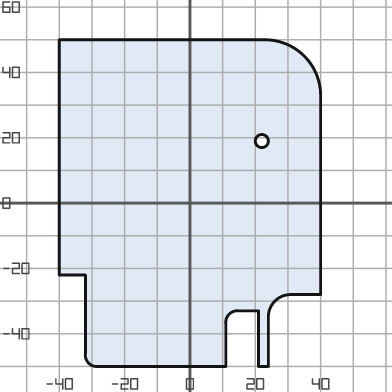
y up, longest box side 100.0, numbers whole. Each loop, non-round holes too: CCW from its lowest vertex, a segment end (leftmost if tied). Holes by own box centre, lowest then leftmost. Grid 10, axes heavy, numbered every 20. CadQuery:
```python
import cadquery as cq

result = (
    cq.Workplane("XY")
    .moveTo(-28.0, -50.0)
    .lineTo(11.0, -50.0)
    .lineTo(11.0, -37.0)
    .threePointArc((12.0, -34.0), (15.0, -33.0))
    .lineTo(21.0, -33.0)
    .lineTo(21.0, -50.0)
    .lineTo(24.0, -50.0)
    .lineTo(24.0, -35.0)
    .threePointArc((26.0, -30.0), (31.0, -28.0))
    .lineTo(40.0, -28.0)
    .lineTo(40.0, 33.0)
    .threePointArc((35.0, 45.0), (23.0, 50.0))
    .lineTo(-40.0, 50.0)
    .lineTo(-40.0, -22.0)
    .lineTo(-32.0, -22.0)
    .lineTo(-32.0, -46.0)
    .threePointArc((-31.0, -49.0), (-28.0, -50.0))
    .close()
    .moveTo(22.0, 19.0)
    .circle(2.0)
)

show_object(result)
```